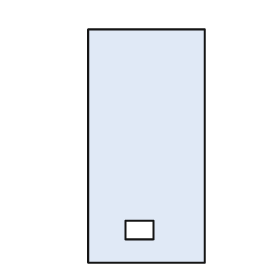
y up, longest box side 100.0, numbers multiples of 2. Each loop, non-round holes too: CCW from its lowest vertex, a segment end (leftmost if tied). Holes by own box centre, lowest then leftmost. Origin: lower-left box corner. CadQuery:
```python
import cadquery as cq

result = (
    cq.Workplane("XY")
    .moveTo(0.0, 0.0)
    .lineTo(50.0, 0.0)
    .lineTo(50.0, 100.0)
    .lineTo(0.0, 100.0)
    .close()
    .moveTo(16.0, 10.0)
    .lineTo(28.0, 10.0)
    .lineTo(28.0, 18.0)
    .lineTo(16.0, 18.0)
    .close()
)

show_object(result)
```